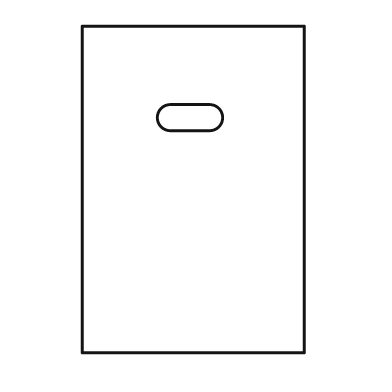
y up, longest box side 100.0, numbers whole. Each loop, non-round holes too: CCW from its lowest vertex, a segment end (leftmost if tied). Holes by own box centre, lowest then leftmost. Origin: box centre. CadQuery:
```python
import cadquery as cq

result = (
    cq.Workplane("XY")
    .moveTo(-34.0, -50.0)
    .lineTo(34.0, -50.0)
    .lineTo(34.0, 50.0)
    .lineTo(-34.0, 50.0)
    .close()
    .moveTo(-7.0, 18.0)
    .lineTo(5.0, 18.0)
    .threePointArc((9.0, 22.0), (5.0, 26.0))
    .lineTo(-7.0, 26.0)
    .threePointArc((-11.0, 22.0), (-7.0, 18.0))
    .close()
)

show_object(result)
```